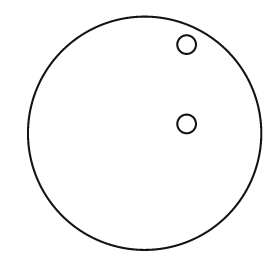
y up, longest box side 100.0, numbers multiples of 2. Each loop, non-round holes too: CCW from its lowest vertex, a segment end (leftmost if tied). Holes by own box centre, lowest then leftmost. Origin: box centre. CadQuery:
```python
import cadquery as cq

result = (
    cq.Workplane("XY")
    .moveTo(0.0, 0.0)
    .circle(50.0)
    .moveTo(18.0, 4.0)
    .circle(4.0)
    .moveTo(18.0, 38.0)
    .circle(4.0)
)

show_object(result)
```